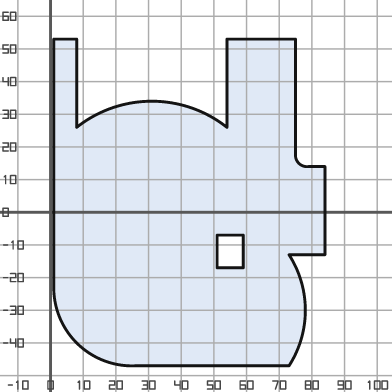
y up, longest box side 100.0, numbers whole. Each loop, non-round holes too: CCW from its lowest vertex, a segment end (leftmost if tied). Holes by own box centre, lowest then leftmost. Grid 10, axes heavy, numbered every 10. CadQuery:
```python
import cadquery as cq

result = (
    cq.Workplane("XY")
    .moveTo(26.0, -47.0)
    .lineTo(73.0, -47.0)
    .threePointArc((78.0, -30.0), (73.0, -13.0))
    .lineTo(84.0, -13.0)
    .lineTo(84.0, 14.0)
    .lineTo(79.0, 14.0)
    .threePointArc((76.0, 15.0), (75.0, 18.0))
    .lineTo(75.0, 53.0)
    .lineTo(54.0, 53.0)
    .lineTo(54.0, 26.0)
    .threePointArc((31.0, 34.0), (8.0, 26.0))
    .lineTo(8.0, 53.0)
    .lineTo(1.0, 53.0)
    .lineTo(1.0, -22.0)
    .threePointArc((8.0, -40.0), (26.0, -47.0))
    .close()
    .moveTo(51.0, -17.0)
    .lineTo(59.0, -17.0)
    .lineTo(59.0, -7.0)
    .lineTo(51.0, -7.0)
    .close()
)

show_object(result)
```